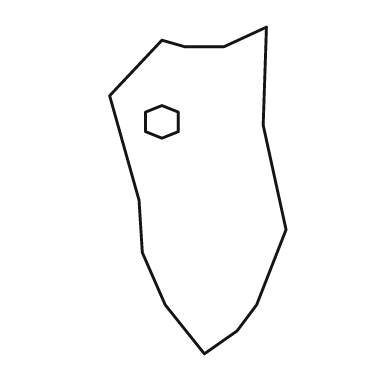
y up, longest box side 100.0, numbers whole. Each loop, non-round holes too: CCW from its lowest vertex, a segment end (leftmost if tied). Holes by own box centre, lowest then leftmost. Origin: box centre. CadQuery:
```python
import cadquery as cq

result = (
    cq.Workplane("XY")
    .moveTo(2.0, -50.0)
    .lineTo(12.0, -43.0)
    .lineTo(18.0, -35.0)
    .lineTo(27.0, -12.0)
    .lineTo(20.0, 20.0)
    .lineTo(21.0, 50.0)
    .lineTo(8.0, 44.0)
    .lineTo(-4.0, 44.0)
    .lineTo(-11.0, 46.0)
    .lineTo(-27.0, 29.0)
    .lineTo(-18.0, -3.0)
    .lineTo(-17.0, -19.0)
    .lineTo(-10.0, -35.0)
    .close()
    .moveTo(-11.0, 16.0)
    .lineTo(-6.0, 18.0)
    .lineTo(-6.0, 24.0)
    .lineTo(-11.0, 26.0)
    .lineTo(-16.0, 24.0)
    .lineTo(-16.0, 18.0)
    .close()
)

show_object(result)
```